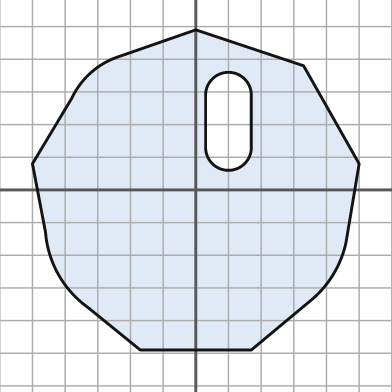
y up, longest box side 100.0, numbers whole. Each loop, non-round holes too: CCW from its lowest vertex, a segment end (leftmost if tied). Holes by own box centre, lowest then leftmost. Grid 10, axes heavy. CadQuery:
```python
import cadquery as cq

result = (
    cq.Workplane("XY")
    .moveTo(-17.0, -49.0)
    .lineTo(17.0, -49.0)
    .lineTo(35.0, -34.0)
    .threePointArc((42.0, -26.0), (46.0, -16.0))
    .lineTo(50.0, 8.0)
    .lineTo(33.0, 38.0)
    .lineTo(0.0, 49.0)
    .lineTo(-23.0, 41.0)
    .threePointArc((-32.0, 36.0), (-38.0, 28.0))
    .lineTo(-50.0, 8.0)
    .lineTo(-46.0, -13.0)
    .threePointArc((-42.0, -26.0), (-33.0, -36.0))
    .close()
    .moveTo(3.0, 13.0)
    .threePointArc((10.0, 6.0), (17.0, 13.0))
    .lineTo(17.0, 29.0)
    .threePointArc((10.0, 36.0), (3.0, 29.0))
    .close()
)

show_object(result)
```